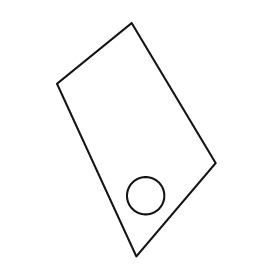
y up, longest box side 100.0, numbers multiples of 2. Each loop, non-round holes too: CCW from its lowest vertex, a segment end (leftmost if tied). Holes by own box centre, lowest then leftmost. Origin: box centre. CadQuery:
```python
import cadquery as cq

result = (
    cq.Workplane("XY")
    .moveTo(0.0, -50.0)
    .lineTo(34.0, -10.0)
    .lineTo(-2.0, 50.0)
    .lineTo(-34.0, 24.0)
    .close()
    .moveTo(4.0, -24.0)
    .circle(8.0)
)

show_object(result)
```